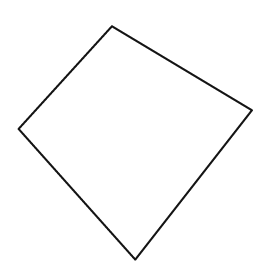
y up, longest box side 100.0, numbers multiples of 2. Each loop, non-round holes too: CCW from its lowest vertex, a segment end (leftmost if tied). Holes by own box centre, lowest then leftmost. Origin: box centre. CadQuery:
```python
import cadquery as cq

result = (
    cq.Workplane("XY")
    .moveTo(0.0, -50.0)
    .lineTo(50.0, 14.0)
    .lineTo(-10.0, 50.0)
    .lineTo(-50.0, 6.0)
    .close()
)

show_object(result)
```